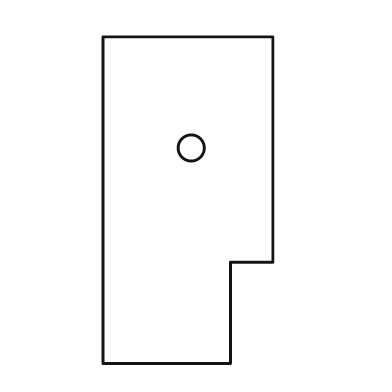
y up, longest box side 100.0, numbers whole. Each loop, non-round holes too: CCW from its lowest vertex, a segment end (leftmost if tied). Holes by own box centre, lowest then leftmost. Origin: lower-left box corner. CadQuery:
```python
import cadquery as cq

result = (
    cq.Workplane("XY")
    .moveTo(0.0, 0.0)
    .lineTo(39.0, 0.0)
    .lineTo(39.0, 31.0)
    .lineTo(52.0, 31.0)
    .lineTo(52.0, 100.0)
    .lineTo(0.0, 100.0)
    .close()
    .moveTo(27.0, 66.0)
    .circle(4.0)
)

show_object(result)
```